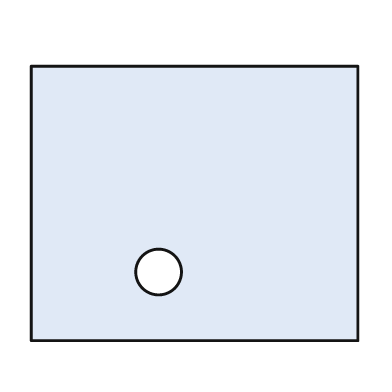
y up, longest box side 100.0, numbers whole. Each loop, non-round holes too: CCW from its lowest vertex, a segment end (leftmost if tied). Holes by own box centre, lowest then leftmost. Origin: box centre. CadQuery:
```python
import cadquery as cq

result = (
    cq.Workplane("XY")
    .moveTo(-50.0, -42.0)
    .lineTo(50.0, -42.0)
    .lineTo(50.0, 42.0)
    .lineTo(-50.0, 42.0)
    .close()
    .moveTo(-11.0, -21.0)
    .circle(7.0)
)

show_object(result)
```